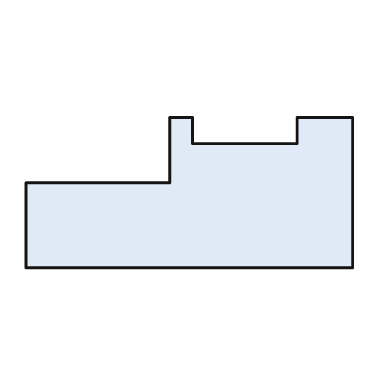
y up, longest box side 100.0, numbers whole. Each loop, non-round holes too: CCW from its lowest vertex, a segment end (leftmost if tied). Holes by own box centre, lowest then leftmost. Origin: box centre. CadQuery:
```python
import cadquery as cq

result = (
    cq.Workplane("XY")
    .moveTo(-50.0, -23.0)
    .lineTo(50.0, -23.0)
    .lineTo(50.0, 23.0)
    .lineTo(33.0, 23.0)
    .lineTo(33.0, 15.0)
    .lineTo(1.0, 15.0)
    .lineTo(1.0, 23.0)
    .lineTo(-6.0, 23.0)
    .lineTo(-6.0, 3.0)
    .lineTo(-50.0, 3.0)
    .close()
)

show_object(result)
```